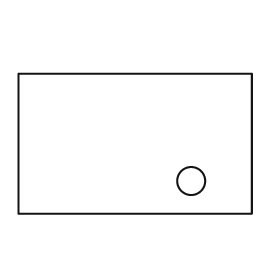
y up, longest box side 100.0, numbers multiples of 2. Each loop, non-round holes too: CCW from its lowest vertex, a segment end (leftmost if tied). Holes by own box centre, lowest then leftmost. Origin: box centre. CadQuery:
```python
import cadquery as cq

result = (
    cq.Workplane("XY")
    .moveTo(-50.0, -30.0)
    .lineTo(50.0, -30.0)
    .lineTo(50.0, 30.0)
    .lineTo(-50.0, 30.0)
    .close()
    .moveTo(24.0, -16.0)
    .circle(6.0)
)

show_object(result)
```